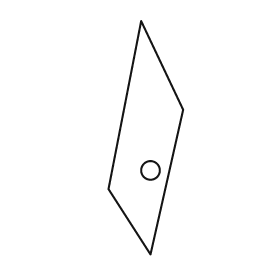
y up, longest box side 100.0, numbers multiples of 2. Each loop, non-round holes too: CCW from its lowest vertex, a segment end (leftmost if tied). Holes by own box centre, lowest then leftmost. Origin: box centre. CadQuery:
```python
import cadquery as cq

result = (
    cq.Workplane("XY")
    .moveTo(2.0, -50.0)
    .lineTo(16.0, 12.0)
    .lineTo(-2.0, 50.0)
    .lineTo(-16.0, -22.0)
    .close()
    .moveTo(2.0, -14.0)
    .circle(4.0)
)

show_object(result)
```